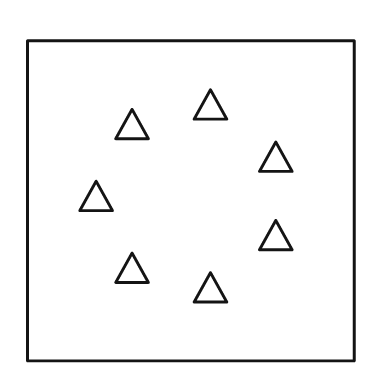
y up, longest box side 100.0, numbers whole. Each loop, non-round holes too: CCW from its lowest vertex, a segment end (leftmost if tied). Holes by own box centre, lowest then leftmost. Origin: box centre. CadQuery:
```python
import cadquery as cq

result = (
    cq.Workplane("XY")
    .moveTo(-50.0, -49.0)
    .lineTo(50.0, -49.0)
    .lineTo(50.0, 49.0)
    .lineTo(-50.0, 49.0)
    .close()
    .moveTo(1.0, -31.0)
    .lineTo(11.0, -31.0)
    .lineTo(6.0, -22.0)
    .close()
    .moveTo(-23.0, -25.0)
    .lineTo(-13.0, -25.0)
    .lineTo(-18.0, -16.0)
    .close()
    .moveTo(21.0, -15.0)
    .lineTo(31.0, -15.0)
    .lineTo(26.0, -6.0)
    .close()
    .moveTo(-34.0, -3.0)
    .lineTo(-24.0, -3.0)
    .lineTo(-29.0, 6.0)
    .close()
    .moveTo(21.0, 9.0)
    .lineTo(31.0, 9.0)
    .lineTo(26.0, 18.0)
    .close()
    .moveTo(-23.0, 19.0)
    .lineTo(-13.0, 19.0)
    .lineTo(-18.0, 28.0)
    .close()
    .moveTo(1.0, 25.0)
    .lineTo(11.0, 25.0)
    .lineTo(6.0, 34.0)
    .close()
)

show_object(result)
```